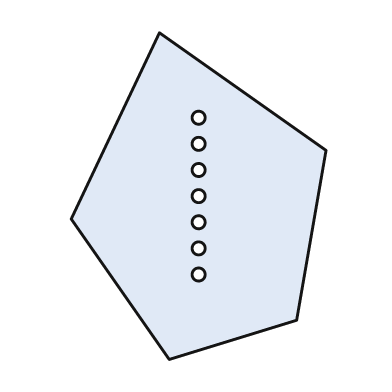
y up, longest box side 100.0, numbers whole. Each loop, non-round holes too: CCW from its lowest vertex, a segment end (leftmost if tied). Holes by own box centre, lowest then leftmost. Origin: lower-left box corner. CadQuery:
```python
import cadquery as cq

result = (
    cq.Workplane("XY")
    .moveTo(30.0, 0.0)
    .lineTo(69.0, 12.0)
    .lineTo(78.0, 64.0)
    .lineTo(27.0, 100.0)
    .lineTo(0.0, 43.0)
    .close()
    .moveTo(39.0, 26.0)
    .circle(2.0)
    .moveTo(39.0, 34.0)
    .circle(2.0)
    .moveTo(39.0, 42.0)
    .circle(2.0)
    .moveTo(39.0, 50.0)
    .circle(2.0)
    .moveTo(39.0, 58.0)
    .circle(2.0)
    .moveTo(39.0, 66.0)
    .circle(2.0)
    .moveTo(39.0, 74.0)
    .circle(2.0)
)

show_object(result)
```